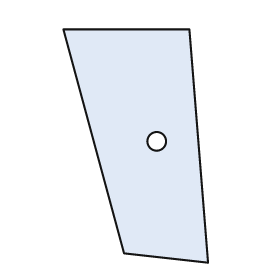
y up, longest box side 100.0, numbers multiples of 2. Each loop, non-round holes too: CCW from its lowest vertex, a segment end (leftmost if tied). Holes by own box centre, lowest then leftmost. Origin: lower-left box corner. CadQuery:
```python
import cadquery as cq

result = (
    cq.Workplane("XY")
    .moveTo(62.0, 0.0)
    .lineTo(54.0, 100.0)
    .lineTo(0.0, 100.0)
    .lineTo(26.0, 4.0)
    .close()
    .moveTo(40.0, 52.0)
    .circle(4.0)
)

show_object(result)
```